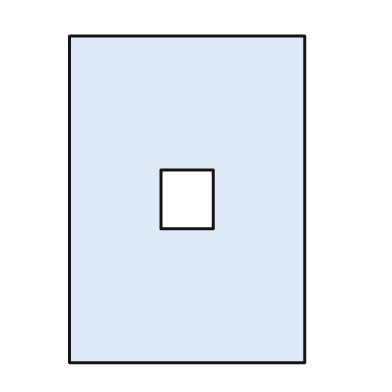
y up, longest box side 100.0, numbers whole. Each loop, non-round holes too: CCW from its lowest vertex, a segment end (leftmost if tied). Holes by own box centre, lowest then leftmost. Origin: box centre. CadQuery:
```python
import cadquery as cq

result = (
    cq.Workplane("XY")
    .moveTo(-36.0, -50.0)
    .lineTo(36.0, -50.0)
    .lineTo(36.0, 50.0)
    .lineTo(-36.0, 50.0)
    .close()
    .moveTo(-8.0, -9.0)
    .lineTo(8.0, -9.0)
    .lineTo(8.0, 9.0)
    .lineTo(-8.0, 9.0)
    .close()
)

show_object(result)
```